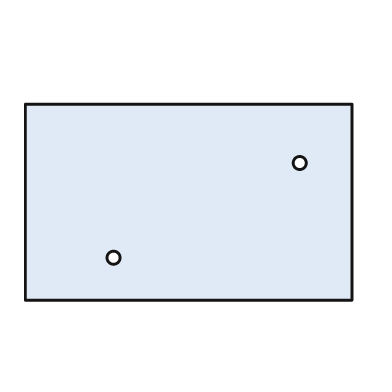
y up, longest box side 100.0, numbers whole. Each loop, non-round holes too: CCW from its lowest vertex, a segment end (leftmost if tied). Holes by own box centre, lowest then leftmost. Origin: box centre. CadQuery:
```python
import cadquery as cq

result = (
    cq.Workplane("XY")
    .moveTo(-50.0, -30.0)
    .lineTo(50.0, -30.0)
    .lineTo(50.0, 30.0)
    .lineTo(-50.0, 30.0)
    .close()
    .moveTo(-23.0, -17.0)
    .circle(2.0)
    .moveTo(34.0, 12.0)
    .circle(2.0)
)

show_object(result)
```